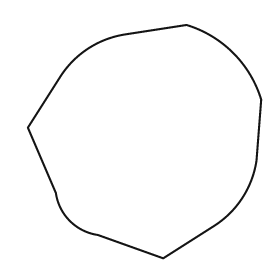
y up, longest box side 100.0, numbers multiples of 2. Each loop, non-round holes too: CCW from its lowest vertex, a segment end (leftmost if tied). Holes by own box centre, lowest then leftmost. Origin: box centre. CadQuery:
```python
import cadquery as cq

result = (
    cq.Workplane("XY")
    .moveTo(8.0, -50.0)
    .lineTo(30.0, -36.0)
    .threePointArc((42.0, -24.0), (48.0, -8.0))
    .lineTo(50.0, 18.0)
    .threePointArc((38.0, 38.0), (18.0, 50.0))
    .lineTo(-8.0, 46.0)
    .threePointArc((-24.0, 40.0), (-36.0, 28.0))
    .lineTo(-50.0, 6.0)
    .lineTo(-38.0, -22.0)
    .threePointArc((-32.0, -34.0), (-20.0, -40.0))
    .close()
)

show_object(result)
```